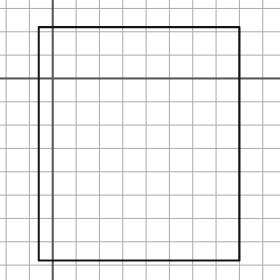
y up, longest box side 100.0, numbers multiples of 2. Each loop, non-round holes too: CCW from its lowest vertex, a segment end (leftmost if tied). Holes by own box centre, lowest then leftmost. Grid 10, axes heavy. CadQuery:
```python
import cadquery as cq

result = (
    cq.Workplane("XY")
    .moveTo(-6.0, -78.0)
    .lineTo(80.0, -78.0)
    .lineTo(80.0, 22.0)
    .lineTo(-6.0, 22.0)
    .close()
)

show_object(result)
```